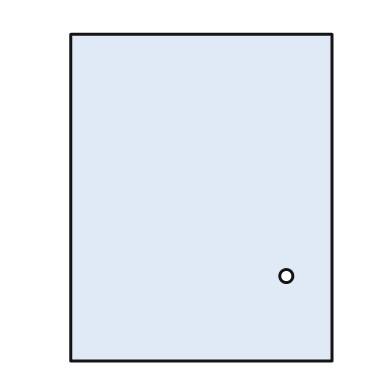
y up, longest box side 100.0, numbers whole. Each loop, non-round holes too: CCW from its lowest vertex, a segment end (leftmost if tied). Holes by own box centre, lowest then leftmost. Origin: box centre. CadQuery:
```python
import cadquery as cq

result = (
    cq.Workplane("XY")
    .moveTo(-40.0, -50.0)
    .lineTo(40.0, -50.0)
    .lineTo(40.0, 50.0)
    .lineTo(-40.0, 50.0)
    .close()
    .moveTo(26.0, -24.0)
    .circle(2.0)
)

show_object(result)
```